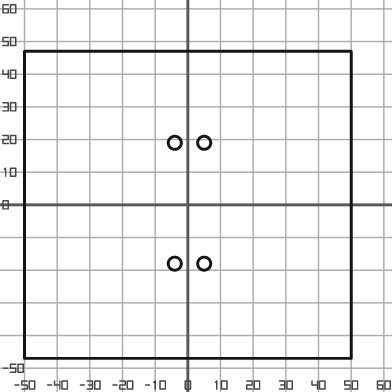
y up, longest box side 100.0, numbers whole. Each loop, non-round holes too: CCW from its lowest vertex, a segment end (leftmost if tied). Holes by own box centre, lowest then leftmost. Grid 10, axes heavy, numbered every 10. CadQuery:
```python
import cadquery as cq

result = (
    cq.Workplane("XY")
    .moveTo(-50.0, -47.0)
    .lineTo(50.0, -47.0)
    .lineTo(50.0, 47.0)
    .lineTo(-50.0, 47.0)
    .close()
    .moveTo(-4.0, -18.0)
    .circle(2.0)
    .moveTo(5.0, -18.0)
    .circle(2.0)
    .moveTo(-4.0, 19.0)
    .circle(2.0)
    .moveTo(5.0, 19.0)
    .circle(2.0)
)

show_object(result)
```